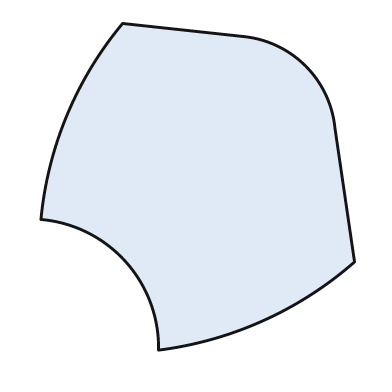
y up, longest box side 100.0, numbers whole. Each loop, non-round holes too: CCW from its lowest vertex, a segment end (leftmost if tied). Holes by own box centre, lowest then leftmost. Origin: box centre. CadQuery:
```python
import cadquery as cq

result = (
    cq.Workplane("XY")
    .moveTo(-12.0, -50.0)
    .threePointArc((20.0, -41.0), (48.0, -23.0))
    .lineTo(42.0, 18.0)
    .threePointArc((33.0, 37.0), (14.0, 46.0))
    .lineTo(-23.0, 50.0)
    .threePointArc((-40.0, 22.0), (-48.0, -10.0))
    .threePointArc((-22.0, -23.0), (-12.0, -50.0))
    .close()
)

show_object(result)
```